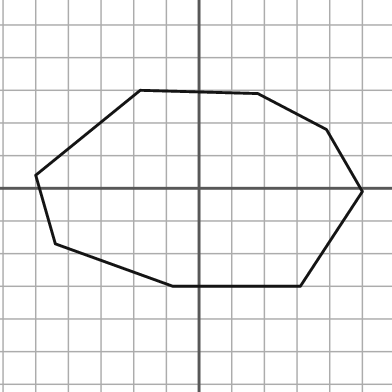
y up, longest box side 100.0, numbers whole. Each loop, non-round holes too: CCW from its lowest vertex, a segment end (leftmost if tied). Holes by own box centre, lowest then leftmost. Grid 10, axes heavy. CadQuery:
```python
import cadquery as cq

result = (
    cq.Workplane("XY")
    .moveTo(-8.0, -30.0)
    .lineTo(31.0, -30.0)
    .lineTo(50.0, -1.0)
    .lineTo(39.0, 18.0)
    .lineTo(18.0, 29.0)
    .lineTo(-18.0, 30.0)
    .lineTo(-50.0, 4.0)
    .lineTo(-44.0, -17.0)
    .close()
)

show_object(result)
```